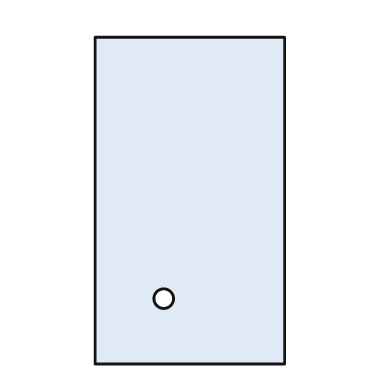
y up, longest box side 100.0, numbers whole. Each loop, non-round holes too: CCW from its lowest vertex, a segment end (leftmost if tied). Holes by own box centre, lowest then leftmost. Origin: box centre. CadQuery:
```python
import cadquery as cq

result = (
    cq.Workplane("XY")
    .moveTo(-29.0, -50.0)
    .lineTo(29.0, -50.0)
    .lineTo(29.0, 50.0)
    .lineTo(-29.0, 50.0)
    .close()
    .moveTo(-8.0, -30.0)
    .circle(3.0)
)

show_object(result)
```